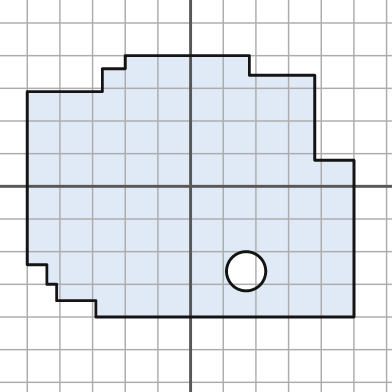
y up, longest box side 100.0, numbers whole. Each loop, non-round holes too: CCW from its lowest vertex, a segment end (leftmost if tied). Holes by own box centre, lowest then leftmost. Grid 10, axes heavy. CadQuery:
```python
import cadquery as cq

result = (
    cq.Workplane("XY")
    .moveTo(-29.0, -40.0)
    .lineTo(50.0, -40.0)
    .lineTo(50.0, 8.0)
    .lineTo(38.0, 8.0)
    .lineTo(38.0, 34.0)
    .lineTo(18.0, 34.0)
    .lineTo(18.0, 40.0)
    .lineTo(-20.0, 40.0)
    .lineTo(-20.0, 36.0)
    .lineTo(-27.0, 36.0)
    .lineTo(-27.0, 29.0)
    .lineTo(-50.0, 29.0)
    .lineTo(-50.0, -24.0)
    .lineTo(-44.0, -24.0)
    .lineTo(-44.0, -30.0)
    .lineTo(-41.0, -30.0)
    .lineTo(-41.0, -35.0)
    .lineTo(-29.0, -35.0)
    .close()
    .moveTo(17.0, -26.0)
    .circle(6.0)
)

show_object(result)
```